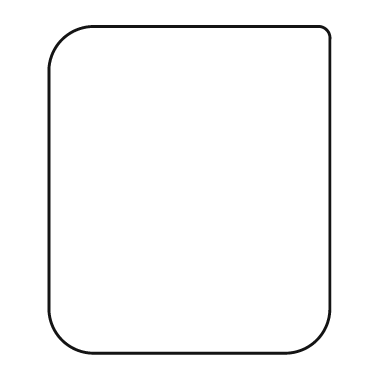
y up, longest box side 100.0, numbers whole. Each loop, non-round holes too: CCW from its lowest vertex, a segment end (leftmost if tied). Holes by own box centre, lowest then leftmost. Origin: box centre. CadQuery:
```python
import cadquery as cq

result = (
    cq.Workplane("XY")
    .moveTo(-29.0, -50.0)
    .lineTo(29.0, -50.0)
    .threePointArc((39.0, -46.0), (43.0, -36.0))
    .lineTo(43.0, 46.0)
    .threePointArc((42.0, 49.0), (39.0, 50.0))
    .lineTo(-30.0, 50.0)
    .threePointArc((-39.0, 46.0), (-43.0, 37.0))
    .lineTo(-43.0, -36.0)
    .threePointArc((-39.0, -46.0), (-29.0, -50.0))
    .close()
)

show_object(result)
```